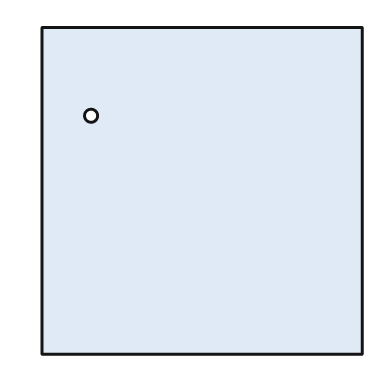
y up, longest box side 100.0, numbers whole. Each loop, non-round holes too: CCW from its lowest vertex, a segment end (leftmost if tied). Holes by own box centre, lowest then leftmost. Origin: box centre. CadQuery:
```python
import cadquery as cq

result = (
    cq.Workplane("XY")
    .moveTo(-49.0, -50.0)
    .lineTo(49.0, -50.0)
    .lineTo(49.0, 50.0)
    .lineTo(-49.0, 50.0)
    .close()
    .moveTo(-34.0, 23.0)
    .circle(2.0)
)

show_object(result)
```